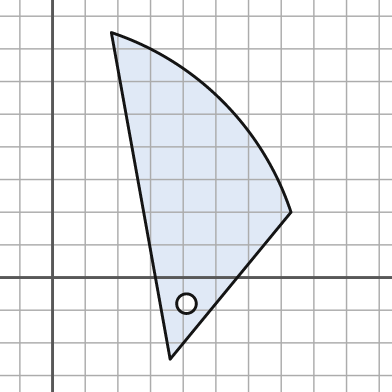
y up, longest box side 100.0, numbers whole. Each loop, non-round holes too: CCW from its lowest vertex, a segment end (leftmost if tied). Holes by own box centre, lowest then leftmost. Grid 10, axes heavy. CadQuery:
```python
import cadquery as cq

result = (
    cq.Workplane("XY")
    .moveTo(36.0, -25.0)
    .lineTo(73.0, 20.0)
    .threePointArc((52.0, 54.0), (18.0, 75.0))
    .close()
    .moveTo(41.0, -8.0)
    .circle(3.0)
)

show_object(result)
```